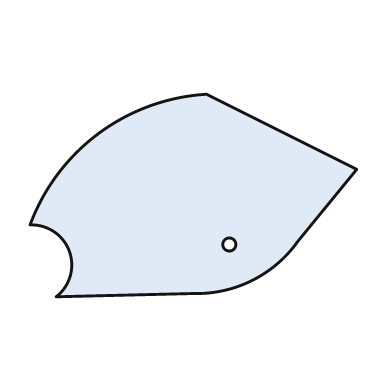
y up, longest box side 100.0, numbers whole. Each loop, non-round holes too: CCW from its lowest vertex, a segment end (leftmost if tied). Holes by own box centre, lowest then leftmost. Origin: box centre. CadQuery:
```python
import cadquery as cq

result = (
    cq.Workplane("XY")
    .moveTo(-42.0, -31.0)
    .lineTo(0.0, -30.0)
    .threePointArc((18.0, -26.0), (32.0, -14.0))
    .lineTo(50.0, 8.0)
    .lineTo(4.0, 31.0)
    .threePointArc((-29.0, 19.0), (-50.0, -9.0))
    .threePointArc((-38.0, -17.0), (-42.0, -31.0))
    .close()
    .moveTo(11.0, -15.0)
    .circle(2.0)
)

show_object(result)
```